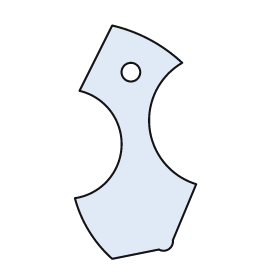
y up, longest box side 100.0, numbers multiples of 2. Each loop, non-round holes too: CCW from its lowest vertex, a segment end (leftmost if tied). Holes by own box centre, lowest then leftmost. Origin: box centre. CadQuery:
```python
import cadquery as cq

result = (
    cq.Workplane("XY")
    .moveTo(-10.0, -50.0)
    .lineTo(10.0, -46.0)
    .threePointArc((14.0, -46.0), (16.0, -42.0))
    .lineTo(26.0, -18.0)
    .threePointArc((6.0, 6.0), (20.0, 34.0))
    .threePointArc((6.0, 44.0), (-10.0, 50.0))
    .lineTo(-24.0, 22.0)
    .threePointArc((-6.0, -2.0), (-26.0, -24.0))
    .threePointArc((-20.0, -38.0), (-10.0, -50.0))
    .close()
    .moveTo(-2.0, 30.0)
    .circle(4.0)
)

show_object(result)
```